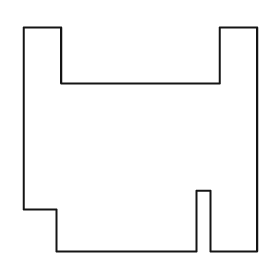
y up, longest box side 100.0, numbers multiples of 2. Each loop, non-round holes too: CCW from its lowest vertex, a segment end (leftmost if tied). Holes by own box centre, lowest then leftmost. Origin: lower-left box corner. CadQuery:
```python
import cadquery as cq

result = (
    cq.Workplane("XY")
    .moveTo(14.0, 0.0)
    .lineTo(74.0, 0.0)
    .lineTo(74.0, 26.0)
    .lineTo(80.0, 26.0)
    .lineTo(80.0, 0.0)
    .lineTo(100.0, 0.0)
    .lineTo(100.0, 96.0)
    .lineTo(84.0, 96.0)
    .lineTo(84.0, 72.0)
    .lineTo(16.0, 72.0)
    .lineTo(16.0, 96.0)
    .lineTo(0.0, 96.0)
    .lineTo(0.0, 18.0)
    .lineTo(14.0, 18.0)
    .close()
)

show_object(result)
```